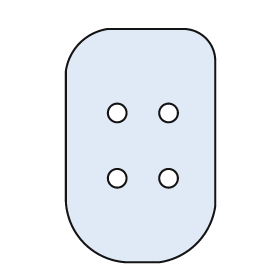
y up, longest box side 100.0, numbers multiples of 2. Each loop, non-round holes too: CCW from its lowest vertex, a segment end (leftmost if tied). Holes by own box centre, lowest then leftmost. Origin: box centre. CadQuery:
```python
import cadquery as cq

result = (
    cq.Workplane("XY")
    .moveTo(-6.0, -50.0)
    .lineTo(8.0, -50.0)
    .threePointArc((24.0, -42.0), (32.0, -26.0))
    .lineTo(32.0, 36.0)
    .threePointArc((28.0, 46.0), (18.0, 50.0))
    .lineTo(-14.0, 50.0)
    .threePointArc((-26.0, 44.0), (-32.0, 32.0))
    .lineTo(-32.0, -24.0)
    .threePointArc((-24.0, -42.0), (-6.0, -50.0))
    .close()
    .moveTo(-10.0, -14.0)
    .circle(4.0)
    .moveTo(12.0, -14.0)
    .circle(4.0)
    .moveTo(-10.0, 14.0)
    .circle(4.0)
    .moveTo(12.0, 14.0)
    .circle(4.0)
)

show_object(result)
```